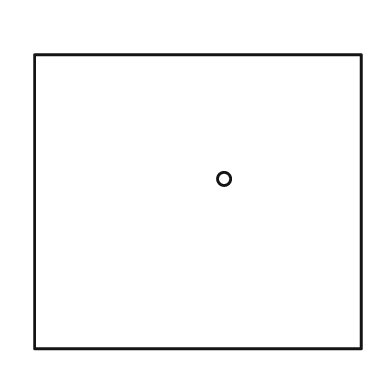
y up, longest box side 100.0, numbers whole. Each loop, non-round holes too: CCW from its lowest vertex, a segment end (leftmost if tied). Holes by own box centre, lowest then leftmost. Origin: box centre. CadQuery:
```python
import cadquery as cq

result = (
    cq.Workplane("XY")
    .moveTo(-50.0, -45.0)
    .lineTo(50.0, -45.0)
    .lineTo(50.0, 45.0)
    .lineTo(-50.0, 45.0)
    .close()
    .moveTo(8.0, 7.0)
    .circle(2.0)
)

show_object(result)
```